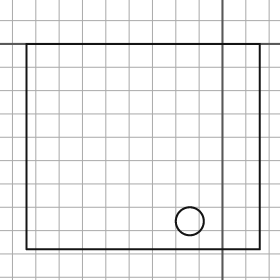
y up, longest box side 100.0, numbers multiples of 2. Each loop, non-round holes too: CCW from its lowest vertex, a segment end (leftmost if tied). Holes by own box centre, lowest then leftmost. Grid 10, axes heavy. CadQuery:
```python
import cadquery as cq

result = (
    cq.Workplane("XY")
    .moveTo(-84.0, -88.0)
    .lineTo(16.0, -88.0)
    .lineTo(16.0, 0.0)
    .lineTo(-84.0, 0.0)
    .close()
    .moveTo(-14.0, -76.0)
    .circle(6.0)
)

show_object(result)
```